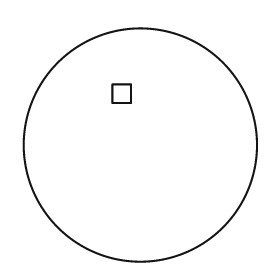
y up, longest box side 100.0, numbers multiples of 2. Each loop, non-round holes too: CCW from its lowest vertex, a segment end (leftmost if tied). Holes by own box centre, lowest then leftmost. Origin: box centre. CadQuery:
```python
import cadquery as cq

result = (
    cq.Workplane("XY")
    .moveTo(0.0, 0.0)
    .circle(50.0)
    .moveTo(-12.0, 18.0)
    .lineTo(-4.0, 18.0)
    .lineTo(-4.0, 26.0)
    .lineTo(-12.0, 26.0)
    .close()
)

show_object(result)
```